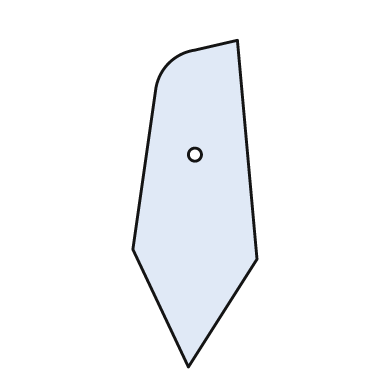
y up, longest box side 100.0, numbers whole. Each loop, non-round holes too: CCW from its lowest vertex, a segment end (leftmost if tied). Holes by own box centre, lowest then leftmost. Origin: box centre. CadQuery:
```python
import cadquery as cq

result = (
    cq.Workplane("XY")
    .moveTo(-2.0, -50.0)
    .lineTo(19.0, -17.0)
    .lineTo(13.0, 50.0)
    .lineTo(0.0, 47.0)
    .threePointArc((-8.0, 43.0), (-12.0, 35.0))
    .lineTo(-19.0, -14.0)
    .close()
    .moveTo(0.0, 15.0)
    .circle(2.0)
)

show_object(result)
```